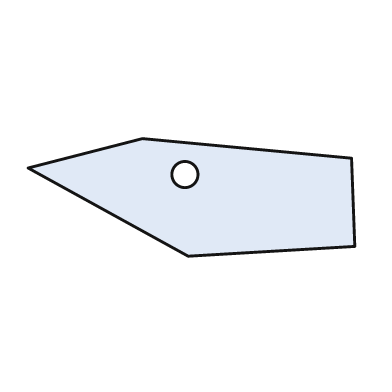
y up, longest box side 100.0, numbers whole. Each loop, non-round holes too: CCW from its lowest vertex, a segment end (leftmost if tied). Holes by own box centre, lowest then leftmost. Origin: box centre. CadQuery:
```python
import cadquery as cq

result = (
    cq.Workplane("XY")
    .moveTo(-1.0, -18.0)
    .lineTo(50.0, -15.0)
    .lineTo(49.0, 12.0)
    .lineTo(-15.0, 18.0)
    .lineTo(-50.0, 9.0)
    .close()
    .moveTo(-2.0, 7.0)
    .circle(4.0)
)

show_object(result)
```